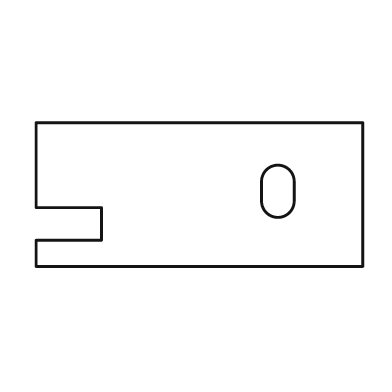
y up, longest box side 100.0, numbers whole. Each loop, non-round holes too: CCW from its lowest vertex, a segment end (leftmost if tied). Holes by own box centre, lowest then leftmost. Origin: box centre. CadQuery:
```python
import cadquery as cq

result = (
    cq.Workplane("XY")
    .moveTo(-50.0, -22.0)
    .lineTo(50.0, -22.0)
    .lineTo(50.0, 22.0)
    .lineTo(-50.0, 22.0)
    .lineTo(-50.0, -4.0)
    .lineTo(-30.0, -4.0)
    .lineTo(-30.0, -14.0)
    .lineTo(-50.0, -14.0)
    .close()
    .moveTo(19.0, -2.0)
    .threePointArc((24.0, -7.0), (29.0, -2.0))
    .lineTo(29.0, 4.0)
    .threePointArc((24.0, 9.0), (19.0, 4.0))
    .close()
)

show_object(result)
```